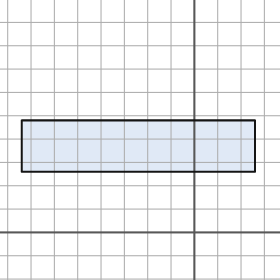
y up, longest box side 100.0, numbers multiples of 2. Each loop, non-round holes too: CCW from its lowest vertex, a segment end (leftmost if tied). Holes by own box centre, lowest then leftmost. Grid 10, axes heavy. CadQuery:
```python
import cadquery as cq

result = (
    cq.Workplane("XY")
    .moveTo(-74.0, 26.0)
    .lineTo(26.0, 26.0)
    .lineTo(26.0, 48.0)
    .lineTo(-74.0, 48.0)
    .close()
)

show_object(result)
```